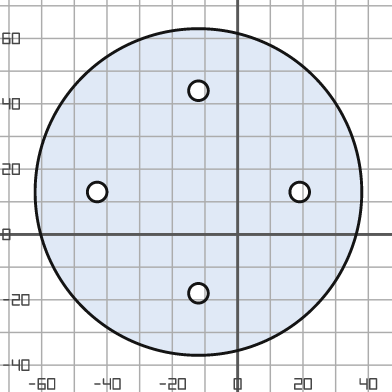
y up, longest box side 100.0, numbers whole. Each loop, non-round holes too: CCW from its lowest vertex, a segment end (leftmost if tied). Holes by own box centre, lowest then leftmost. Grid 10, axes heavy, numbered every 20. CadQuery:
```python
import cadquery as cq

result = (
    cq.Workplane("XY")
    .moveTo(-12.0, 13.0)
    .circle(50.0)
    .moveTo(-12.0, -18.0)
    .circle(3.0)
    .moveTo(-43.0, 13.0)
    .circle(3.0)
    .moveTo(19.0, 13.0)
    .circle(3.0)
    .moveTo(-12.0, 44.0)
    .circle(3.0)
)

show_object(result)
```